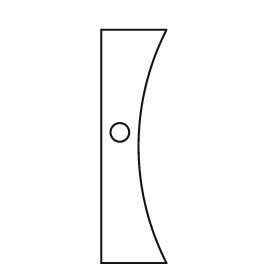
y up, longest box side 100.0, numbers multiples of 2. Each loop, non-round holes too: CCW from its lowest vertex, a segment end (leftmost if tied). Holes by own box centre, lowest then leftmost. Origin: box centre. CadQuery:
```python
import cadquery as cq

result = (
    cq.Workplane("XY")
    .moveTo(-14.0, -50.0)
    .lineTo(14.0, -50.0)
    .threePointArc((2.0, 0.0), (14.0, 50.0))
    .lineTo(-14.0, 50.0)
    .close()
    .moveTo(-6.0, 6.0)
    .circle(4.0)
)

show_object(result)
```